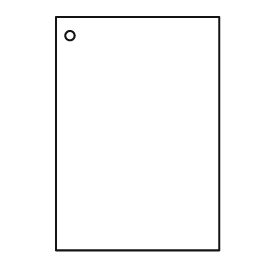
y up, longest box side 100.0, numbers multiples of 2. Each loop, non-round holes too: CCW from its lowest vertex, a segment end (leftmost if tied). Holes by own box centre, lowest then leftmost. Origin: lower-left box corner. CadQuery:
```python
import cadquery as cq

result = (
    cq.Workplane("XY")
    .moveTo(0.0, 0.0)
    .lineTo(70.0, 0.0)
    .lineTo(70.0, 100.0)
    .lineTo(0.0, 100.0)
    .close()
    .moveTo(6.0, 92.0)
    .circle(2.0)
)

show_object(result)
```